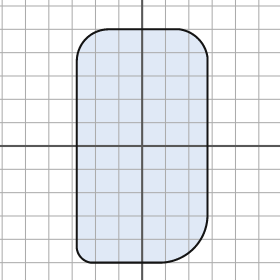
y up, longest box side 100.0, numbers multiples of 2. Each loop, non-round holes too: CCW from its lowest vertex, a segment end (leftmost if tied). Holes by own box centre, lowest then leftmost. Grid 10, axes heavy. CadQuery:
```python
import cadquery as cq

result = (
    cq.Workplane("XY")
    .moveTo(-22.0, -50.0)
    .lineTo(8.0, -50.0)
    .threePointArc((22.0, -44.0), (28.0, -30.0))
    .lineTo(28.0, 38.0)
    .threePointArc((24.0, 46.0), (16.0, 50.0))
    .lineTo(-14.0, 50.0)
    .threePointArc((-24.0, 46.0), (-28.0, 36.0))
    .lineTo(-28.0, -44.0)
    .threePointArc((-26.0, -48.0), (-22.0, -50.0))
    .close()
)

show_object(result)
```